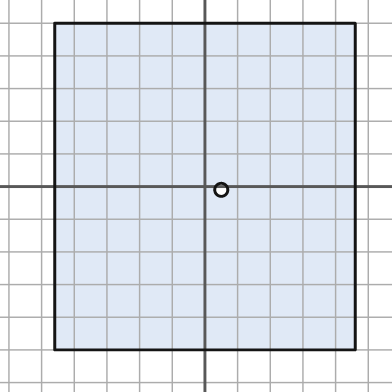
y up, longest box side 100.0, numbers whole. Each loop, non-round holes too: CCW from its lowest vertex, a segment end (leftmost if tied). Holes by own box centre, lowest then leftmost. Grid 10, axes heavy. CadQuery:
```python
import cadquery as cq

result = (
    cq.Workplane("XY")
    .moveTo(-46.0, -50.0)
    .lineTo(46.0, -50.0)
    .lineTo(46.0, 50.0)
    .lineTo(-46.0, 50.0)
    .close()
    .moveTo(5.0, -1.0)
    .circle(2.0)
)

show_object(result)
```